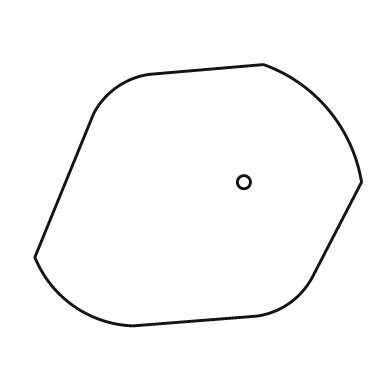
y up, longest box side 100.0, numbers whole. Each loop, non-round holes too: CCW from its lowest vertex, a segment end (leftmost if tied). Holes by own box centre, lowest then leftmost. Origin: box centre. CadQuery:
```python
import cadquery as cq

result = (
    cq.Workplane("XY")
    .moveTo(-20.0, -40.0)
    .lineTo(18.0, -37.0)
    .threePointArc((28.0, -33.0), (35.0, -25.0))
    .lineTo(50.0, 4.0)
    .threePointArc((40.0, 26.0), (20.0, 40.0))
    .lineTo(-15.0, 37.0)
    .threePointArc((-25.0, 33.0), (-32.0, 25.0))
    .lineTo(-50.0, -19.0)
    .threePointArc((-38.0, -34.0), (-20.0, -40.0))
    .close()
    .moveTo(14.0, 4.0)
    .circle(2.0)
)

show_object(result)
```